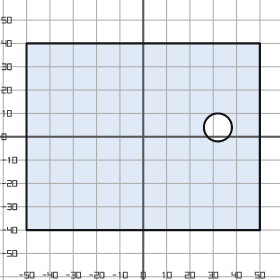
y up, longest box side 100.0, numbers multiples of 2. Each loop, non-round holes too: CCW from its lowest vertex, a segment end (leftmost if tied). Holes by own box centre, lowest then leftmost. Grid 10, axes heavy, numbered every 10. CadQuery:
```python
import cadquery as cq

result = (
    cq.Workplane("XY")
    .moveTo(-50.0, -40.0)
    .lineTo(50.0, -40.0)
    .lineTo(50.0, 40.0)
    .lineTo(-50.0, 40.0)
    .close()
    .moveTo(32.0, 4.0)
    .circle(6.0)
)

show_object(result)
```